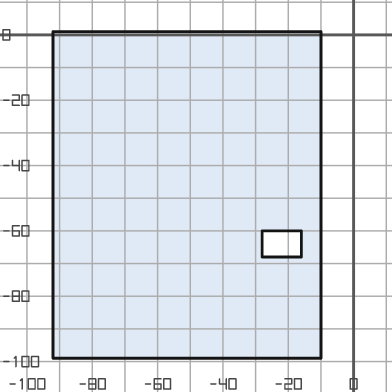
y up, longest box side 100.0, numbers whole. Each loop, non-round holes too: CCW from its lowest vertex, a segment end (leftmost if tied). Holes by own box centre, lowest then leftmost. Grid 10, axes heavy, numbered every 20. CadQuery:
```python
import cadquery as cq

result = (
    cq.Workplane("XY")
    .moveTo(-92.0, -99.0)
    .lineTo(-10.0, -99.0)
    .lineTo(-10.0, 1.0)
    .lineTo(-92.0, 1.0)
    .close()
    .moveTo(-28.0, -68.0)
    .lineTo(-16.0, -68.0)
    .lineTo(-16.0, -60.0)
    .lineTo(-28.0, -60.0)
    .close()
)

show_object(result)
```